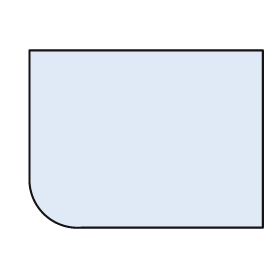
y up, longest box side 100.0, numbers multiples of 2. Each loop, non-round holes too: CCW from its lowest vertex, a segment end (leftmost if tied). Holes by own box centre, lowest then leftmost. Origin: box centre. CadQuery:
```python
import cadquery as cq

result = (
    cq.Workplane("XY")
    .moveTo(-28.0, -38.0)
    .lineTo(50.0, -38.0)
    .lineTo(50.0, 38.0)
    .lineTo(-50.0, 38.0)
    .lineTo(-50.0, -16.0)
    .threePointArc((-44.0, -32.0), (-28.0, -38.0))
    .close()
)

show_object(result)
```